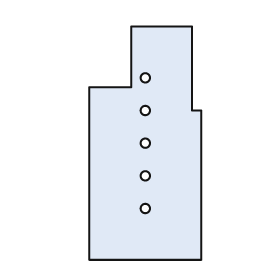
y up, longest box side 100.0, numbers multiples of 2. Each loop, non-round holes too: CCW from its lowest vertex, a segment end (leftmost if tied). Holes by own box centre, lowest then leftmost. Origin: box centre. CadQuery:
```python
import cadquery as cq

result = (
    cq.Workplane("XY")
    .moveTo(-24.0, -50.0)
    .lineTo(24.0, -50.0)
    .lineTo(24.0, 14.0)
    .lineTo(20.0, 14.0)
    .lineTo(20.0, 50.0)
    .lineTo(-6.0, 50.0)
    .lineTo(-6.0, 24.0)
    .lineTo(-24.0, 24.0)
    .close()
    .moveTo(0.0, -28.0)
    .circle(2.0)
    .moveTo(0.0, -14.0)
    .circle(2.0)
    .moveTo(0.0, 0.0)
    .circle(2.0)
    .moveTo(0.0, 14.0)
    .circle(2.0)
    .moveTo(0.0, 28.0)
    .circle(2.0)
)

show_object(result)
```